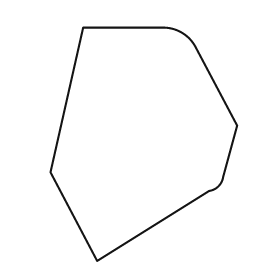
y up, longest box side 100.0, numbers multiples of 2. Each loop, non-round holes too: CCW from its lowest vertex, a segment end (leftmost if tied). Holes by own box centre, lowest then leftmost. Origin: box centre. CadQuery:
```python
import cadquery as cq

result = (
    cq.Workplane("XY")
    .moveTo(-20.0, -50.0)
    .lineTo(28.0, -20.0)
    .threePointArc((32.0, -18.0), (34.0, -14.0))
    .lineTo(40.0, 8.0)
    .lineTo(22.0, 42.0)
    .threePointArc((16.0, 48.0), (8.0, 50.0))
    .lineTo(-26.0, 50.0)
    .lineTo(-40.0, -12.0)
    .close()
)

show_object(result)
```